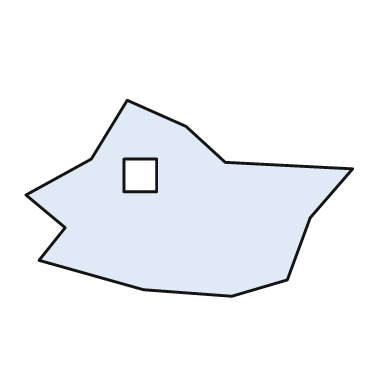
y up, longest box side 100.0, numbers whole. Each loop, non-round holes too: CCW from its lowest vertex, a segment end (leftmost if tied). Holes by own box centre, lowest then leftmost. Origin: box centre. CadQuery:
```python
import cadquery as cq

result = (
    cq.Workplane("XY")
    .moveTo(13.0, -30.0)
    .lineTo(30.0, -25.0)
    .lineTo(37.0, -6.0)
    .lineTo(50.0, 9.0)
    .lineTo(11.0, 11.0)
    .lineTo(-1.0, 22.0)
    .lineTo(-19.0, 30.0)
    .lineTo(-30.0, 12.0)
    .lineTo(-50.0, 1.0)
    .lineTo(-38.0, -9.0)
    .lineTo(-46.0, -19.0)
    .lineTo(-14.0, -28.0)
    .close()
    .moveTo(-20.0, 2.0)
    .lineTo(-10.0, 2.0)
    .lineTo(-10.0, 12.0)
    .lineTo(-20.0, 12.0)
    .close()
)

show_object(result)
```